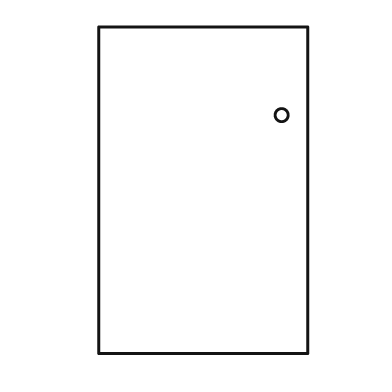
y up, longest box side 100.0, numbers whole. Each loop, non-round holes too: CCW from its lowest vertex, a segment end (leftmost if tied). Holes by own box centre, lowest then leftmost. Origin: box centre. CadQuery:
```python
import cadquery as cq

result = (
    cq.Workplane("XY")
    .moveTo(-32.0, -50.0)
    .lineTo(32.0, -50.0)
    .lineTo(32.0, 50.0)
    .lineTo(-32.0, 50.0)
    .close()
    .moveTo(24.0, 23.0)
    .circle(2.0)
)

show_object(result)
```